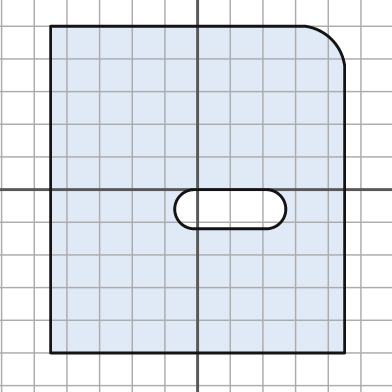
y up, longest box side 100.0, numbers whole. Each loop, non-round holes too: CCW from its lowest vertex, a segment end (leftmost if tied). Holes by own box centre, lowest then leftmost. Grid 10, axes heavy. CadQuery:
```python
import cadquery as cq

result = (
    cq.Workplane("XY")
    .moveTo(-45.0, -50.0)
    .lineTo(45.0, -50.0)
    .lineTo(45.0, 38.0)
    .threePointArc((41.0, 46.0), (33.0, 50.0))
    .lineTo(-45.0, 50.0)
    .close()
    .moveTo(-1.0, -12.0)
    .lineTo(21.0, -12.0)
    .threePointArc((27.0, -6.0), (21.0, 0.0))
    .lineTo(-1.0, 0.0)
    .threePointArc((-7.0, -6.0), (-1.0, -12.0))
    .close()
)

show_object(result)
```